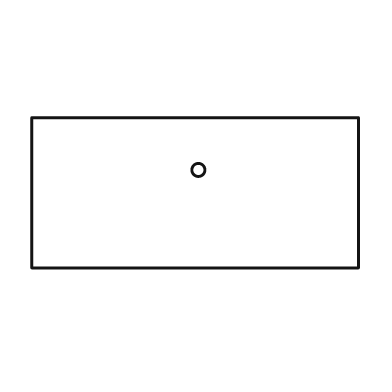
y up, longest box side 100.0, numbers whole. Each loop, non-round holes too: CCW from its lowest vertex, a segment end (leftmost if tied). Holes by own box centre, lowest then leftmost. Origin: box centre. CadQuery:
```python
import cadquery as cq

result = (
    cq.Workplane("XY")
    .moveTo(-50.0, -23.0)
    .lineTo(50.0, -23.0)
    .lineTo(50.0, 23.0)
    .lineTo(-50.0, 23.0)
    .close()
    .moveTo(1.0, 7.0)
    .circle(2.0)
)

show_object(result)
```